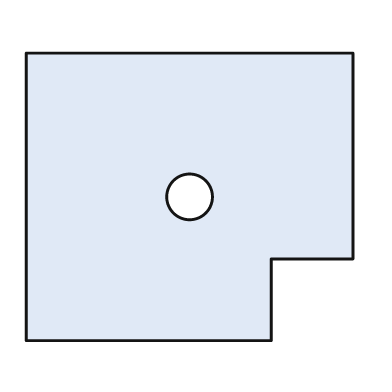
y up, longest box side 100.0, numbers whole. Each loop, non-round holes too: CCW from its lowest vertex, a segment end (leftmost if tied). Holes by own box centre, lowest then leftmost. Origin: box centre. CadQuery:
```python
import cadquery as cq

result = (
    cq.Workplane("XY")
    .moveTo(-50.0, -44.0)
    .lineTo(25.0, -44.0)
    .lineTo(25.0, -19.0)
    .lineTo(50.0, -19.0)
    .lineTo(50.0, 44.0)
    .lineTo(-50.0, 44.0)
    .close()
    .moveTo(0.0, 0.0)
    .circle(7.0)
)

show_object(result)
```